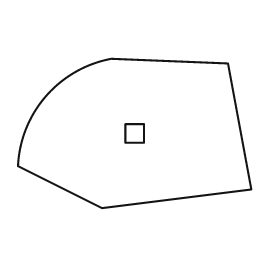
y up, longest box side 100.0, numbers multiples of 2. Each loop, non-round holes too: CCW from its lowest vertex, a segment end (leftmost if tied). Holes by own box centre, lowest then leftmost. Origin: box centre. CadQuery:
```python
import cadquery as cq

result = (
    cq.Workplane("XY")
    .moveTo(-14.0, -32.0)
    .lineTo(50.0, -24.0)
    .lineTo(40.0, 30.0)
    .lineTo(-10.0, 32.0)
    .threePointArc((-38.0, 16.0), (-50.0, -14.0))
    .close()
    .moveTo(-4.0, -4.0)
    .lineTo(4.0, -4.0)
    .lineTo(4.0, 4.0)
    .lineTo(-4.0, 4.0)
    .close()
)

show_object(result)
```